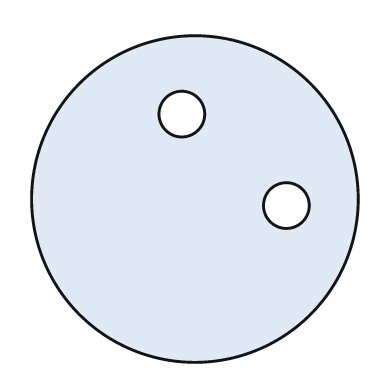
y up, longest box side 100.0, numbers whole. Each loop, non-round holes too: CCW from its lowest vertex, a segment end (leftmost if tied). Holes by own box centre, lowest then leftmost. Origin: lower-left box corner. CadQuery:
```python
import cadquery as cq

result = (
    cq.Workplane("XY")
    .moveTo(50.0, 50.0)
    .circle(50.0)
    .moveTo(78.0, 48.0)
    .circle(7.0)
    .moveTo(46.0, 76.0)
    .circle(7.0)
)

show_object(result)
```